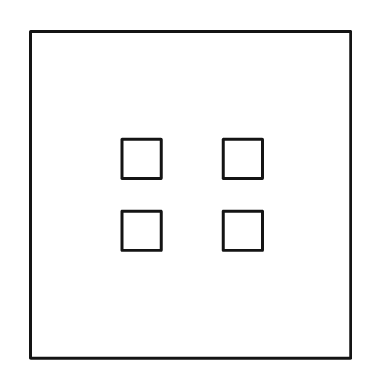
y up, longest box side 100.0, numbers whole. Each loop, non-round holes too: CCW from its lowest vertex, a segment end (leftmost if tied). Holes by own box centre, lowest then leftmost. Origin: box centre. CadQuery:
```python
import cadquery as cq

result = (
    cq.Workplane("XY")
    .moveTo(-49.0, -50.0)
    .lineTo(49.0, -50.0)
    .lineTo(49.0, 50.0)
    .lineTo(-49.0, 50.0)
    .close()
    .moveTo(-21.0, -17.0)
    .lineTo(-9.0, -17.0)
    .lineTo(-9.0, -5.0)
    .lineTo(-21.0, -5.0)
    .close()
    .moveTo(10.0, -17.0)
    .lineTo(22.0, -17.0)
    .lineTo(22.0, -5.0)
    .lineTo(10.0, -5.0)
    .close()
    .moveTo(-21.0, 5.0)
    .lineTo(-9.0, 5.0)
    .lineTo(-9.0, 17.0)
    .lineTo(-21.0, 17.0)
    .close()
    .moveTo(10.0, 5.0)
    .lineTo(22.0, 5.0)
    .lineTo(22.0, 17.0)
    .lineTo(10.0, 17.0)
    .close()
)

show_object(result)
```